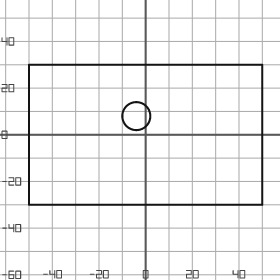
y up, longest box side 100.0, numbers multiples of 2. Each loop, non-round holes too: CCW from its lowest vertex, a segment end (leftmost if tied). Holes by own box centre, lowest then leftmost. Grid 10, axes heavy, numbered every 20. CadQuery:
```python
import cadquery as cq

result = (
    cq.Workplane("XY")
    .moveTo(-50.0, -30.0)
    .lineTo(50.0, -30.0)
    .lineTo(50.0, 30.0)
    .lineTo(-50.0, 30.0)
    .close()
    .moveTo(-4.0, 8.0)
    .circle(6.0)
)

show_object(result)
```